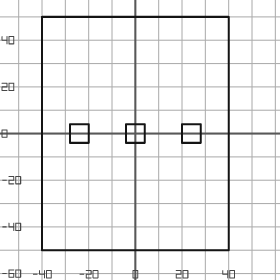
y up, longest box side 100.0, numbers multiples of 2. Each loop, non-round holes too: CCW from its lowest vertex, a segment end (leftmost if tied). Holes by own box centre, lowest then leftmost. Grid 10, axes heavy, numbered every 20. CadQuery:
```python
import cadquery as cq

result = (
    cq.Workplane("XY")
    .moveTo(-40.0, -50.0)
    .lineTo(40.0, -50.0)
    .lineTo(40.0, 50.0)
    .lineTo(-40.0, 50.0)
    .close()
    .moveTo(-28.0, -4.0)
    .lineTo(-20.0, -4.0)
    .lineTo(-20.0, 4.0)
    .lineTo(-28.0, 4.0)
    .close()
    .moveTo(-4.0, -4.0)
    .lineTo(4.0, -4.0)
    .lineTo(4.0, 4.0)
    .lineTo(-4.0, 4.0)
    .close()
    .moveTo(20.0, -4.0)
    .lineTo(28.0, -4.0)
    .lineTo(28.0, 4.0)
    .lineTo(20.0, 4.0)
    .close()
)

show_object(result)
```